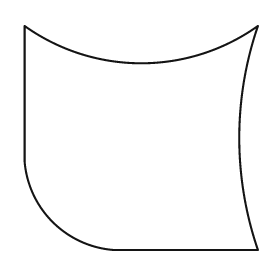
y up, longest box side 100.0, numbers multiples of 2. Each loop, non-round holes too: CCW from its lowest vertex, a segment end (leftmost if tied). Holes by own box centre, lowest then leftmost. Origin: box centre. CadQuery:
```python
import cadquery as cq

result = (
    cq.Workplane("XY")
    .moveTo(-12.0, -48.0)
    .lineTo(50.0, -48.0)
    .threePointArc((42.0, 0.0), (50.0, 48.0))
    .threePointArc((0.0, 32.0), (-50.0, 48.0))
    .lineTo(-50.0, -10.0)
    .threePointArc((-38.0, -36.0), (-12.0, -48.0))
    .close()
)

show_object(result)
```